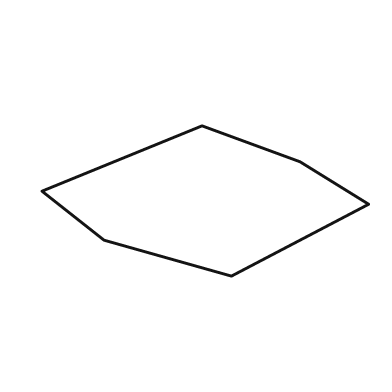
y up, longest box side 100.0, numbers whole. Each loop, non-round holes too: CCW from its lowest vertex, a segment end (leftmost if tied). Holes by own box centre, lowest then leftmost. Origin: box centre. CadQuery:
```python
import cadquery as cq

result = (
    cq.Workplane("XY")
    .moveTo(8.0, -23.0)
    .lineTo(50.0, -1.0)
    .lineTo(29.0, 12.0)
    .lineTo(-1.0, 23.0)
    .lineTo(-50.0, 3.0)
    .lineTo(-31.0, -12.0)
    .close()
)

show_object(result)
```